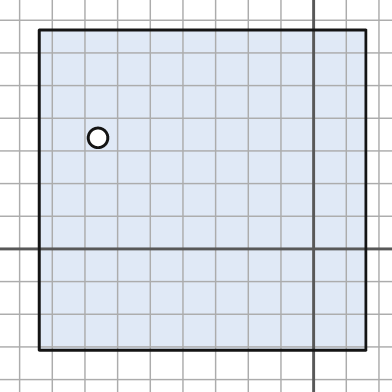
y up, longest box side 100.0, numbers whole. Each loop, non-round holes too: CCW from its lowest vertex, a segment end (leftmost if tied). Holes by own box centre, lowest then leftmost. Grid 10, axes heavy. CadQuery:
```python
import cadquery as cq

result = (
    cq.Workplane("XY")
    .moveTo(-84.0, -31.0)
    .lineTo(16.0, -31.0)
    .lineTo(16.0, 67.0)
    .lineTo(-84.0, 67.0)
    .close()
    .moveTo(-66.0, 34.0)
    .circle(3.0)
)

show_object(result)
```